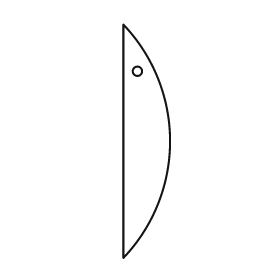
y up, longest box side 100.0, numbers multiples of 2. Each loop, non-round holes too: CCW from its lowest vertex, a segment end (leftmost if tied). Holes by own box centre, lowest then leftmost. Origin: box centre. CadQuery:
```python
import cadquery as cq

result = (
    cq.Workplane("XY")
    .moveTo(-10.0, -50.0)
    .threePointArc((10.0, 0.0), (-10.0, 50.0))
    .close()
    .moveTo(-4.0, 30.0)
    .circle(2.0)
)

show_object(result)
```